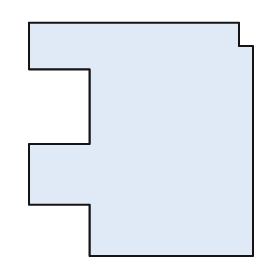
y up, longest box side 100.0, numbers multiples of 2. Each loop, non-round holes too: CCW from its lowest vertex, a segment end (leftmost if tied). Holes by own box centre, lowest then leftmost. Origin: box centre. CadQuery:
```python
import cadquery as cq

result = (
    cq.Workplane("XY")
    .moveTo(-22.0, -50.0)
    .lineTo(48.0, -50.0)
    .lineTo(48.0, 40.0)
    .lineTo(42.0, 40.0)
    .lineTo(42.0, 50.0)
    .lineTo(-48.0, 50.0)
    .lineTo(-48.0, 30.0)
    .lineTo(-22.0, 30.0)
    .lineTo(-22.0, -2.0)
    .lineTo(-48.0, -2.0)
    .lineTo(-48.0, -28.0)
    .lineTo(-22.0, -28.0)
    .close()
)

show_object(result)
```